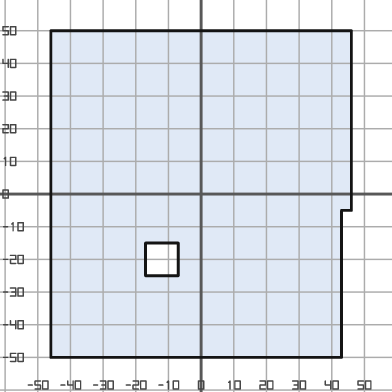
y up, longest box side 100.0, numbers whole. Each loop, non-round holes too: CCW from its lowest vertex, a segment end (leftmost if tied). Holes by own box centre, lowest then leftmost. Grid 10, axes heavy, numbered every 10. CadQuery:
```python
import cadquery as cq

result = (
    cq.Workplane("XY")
    .moveTo(-46.0, -50.0)
    .lineTo(43.0, -50.0)
    .lineTo(43.0, -5.0)
    .lineTo(46.0, -5.0)
    .lineTo(46.0, 50.0)
    .lineTo(-46.0, 50.0)
    .close()
    .moveTo(-17.0, -25.0)
    .lineTo(-7.0, -25.0)
    .lineTo(-7.0, -15.0)
    .lineTo(-17.0, -15.0)
    .close()
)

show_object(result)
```